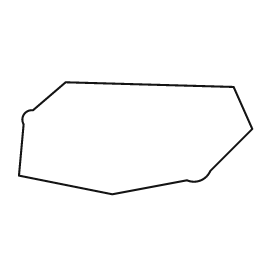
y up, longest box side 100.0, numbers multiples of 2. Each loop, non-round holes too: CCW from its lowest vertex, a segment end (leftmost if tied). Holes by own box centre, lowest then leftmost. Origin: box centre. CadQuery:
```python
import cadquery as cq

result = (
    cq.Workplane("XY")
    .moveTo(-10.0, -24.0)
    .lineTo(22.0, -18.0)
    .threePointArc((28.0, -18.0), (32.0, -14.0))
    .lineTo(50.0, 4.0)
    .lineTo(42.0, 22.0)
    .lineTo(-30.0, 24.0)
    .lineTo(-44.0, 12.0)
    .threePointArc((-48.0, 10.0), (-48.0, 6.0))
    .lineTo(-50.0, -16.0)
    .close()
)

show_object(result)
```